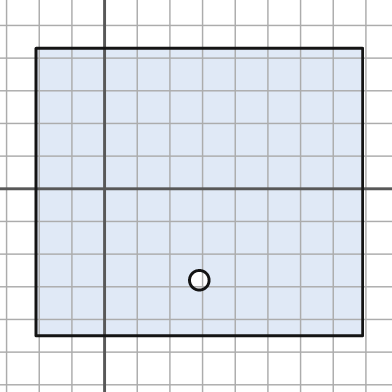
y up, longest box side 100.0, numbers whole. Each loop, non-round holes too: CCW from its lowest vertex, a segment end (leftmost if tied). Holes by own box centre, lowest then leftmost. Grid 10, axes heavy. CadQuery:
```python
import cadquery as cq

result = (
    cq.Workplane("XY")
    .moveTo(-21.0, -45.0)
    .lineTo(79.0, -45.0)
    .lineTo(79.0, 43.0)
    .lineTo(-21.0, 43.0)
    .close()
    .moveTo(29.0, -28.0)
    .circle(3.0)
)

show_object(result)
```